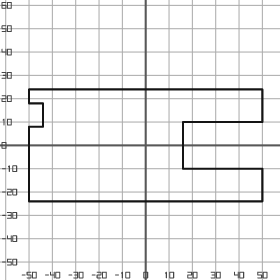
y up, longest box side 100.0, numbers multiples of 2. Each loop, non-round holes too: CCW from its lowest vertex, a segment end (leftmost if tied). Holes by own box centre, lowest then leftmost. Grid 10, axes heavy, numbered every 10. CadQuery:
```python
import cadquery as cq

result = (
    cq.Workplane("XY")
    .moveTo(-50.0, -24.0)
    .lineTo(50.0, -24.0)
    .lineTo(50.0, -10.0)
    .lineTo(16.0, -10.0)
    .lineTo(16.0, 10.0)
    .lineTo(50.0, 10.0)
    .lineTo(50.0, 24.0)
    .lineTo(-50.0, 24.0)
    .lineTo(-50.0, 18.0)
    .lineTo(-44.0, 18.0)
    .lineTo(-44.0, 8.0)
    .lineTo(-50.0, 8.0)
    .close()
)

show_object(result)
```